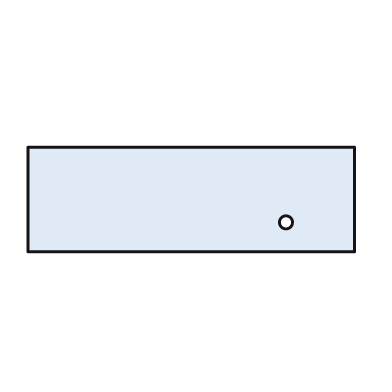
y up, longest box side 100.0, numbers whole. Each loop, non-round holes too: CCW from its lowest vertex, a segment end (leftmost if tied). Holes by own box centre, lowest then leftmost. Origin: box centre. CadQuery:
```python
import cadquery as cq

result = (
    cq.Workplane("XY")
    .moveTo(-50.0, -16.0)
    .lineTo(50.0, -16.0)
    .lineTo(50.0, 16.0)
    .lineTo(-50.0, 16.0)
    .close()
    .moveTo(29.0, -7.0)
    .circle(2.0)
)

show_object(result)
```